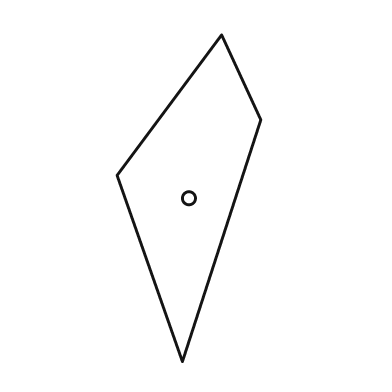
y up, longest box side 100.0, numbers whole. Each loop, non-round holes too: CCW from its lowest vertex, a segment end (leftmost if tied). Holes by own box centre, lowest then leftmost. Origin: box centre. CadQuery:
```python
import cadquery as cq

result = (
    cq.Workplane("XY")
    .moveTo(-2.0, -50.0)
    .lineTo(22.0, 24.0)
    .lineTo(10.0, 50.0)
    .lineTo(-22.0, 7.0)
    .close()
    .moveTo(0.0, 0.0)
    .circle(2.0)
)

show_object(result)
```